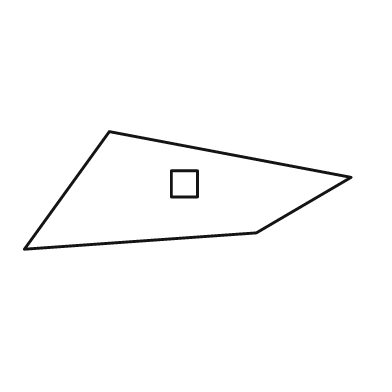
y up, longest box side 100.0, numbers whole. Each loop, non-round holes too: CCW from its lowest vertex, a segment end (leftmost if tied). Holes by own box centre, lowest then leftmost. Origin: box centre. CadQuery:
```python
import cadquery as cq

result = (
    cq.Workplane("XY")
    .moveTo(-50.0, -18.0)
    .lineTo(21.0, -13.0)
    .lineTo(50.0, 4.0)
    .lineTo(-24.0, 18.0)
    .close()
    .moveTo(-5.0, -2.0)
    .lineTo(3.0, -2.0)
    .lineTo(3.0, 6.0)
    .lineTo(-5.0, 6.0)
    .close()
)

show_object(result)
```